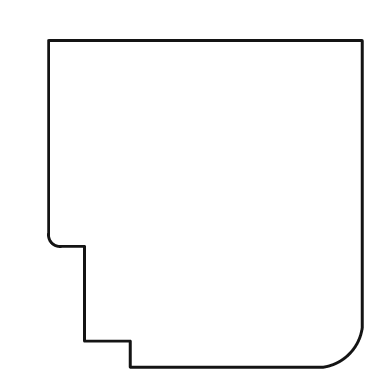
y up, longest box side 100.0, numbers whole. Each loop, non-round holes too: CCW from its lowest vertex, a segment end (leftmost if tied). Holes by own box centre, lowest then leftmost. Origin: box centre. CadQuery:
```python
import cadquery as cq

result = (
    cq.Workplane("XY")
    .moveTo(-23.0, -50.0)
    .lineTo(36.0, -50.0)
    .threePointArc((44.0, -46.0), (48.0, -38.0))
    .lineTo(48.0, 50.0)
    .lineTo(-48.0, 50.0)
    .lineTo(-48.0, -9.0)
    .threePointArc((-47.0, -12.0), (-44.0, -13.0))
    .lineTo(-37.0, -13.0)
    .lineTo(-37.0, -42.0)
    .lineTo(-23.0, -42.0)
    .close()
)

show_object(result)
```